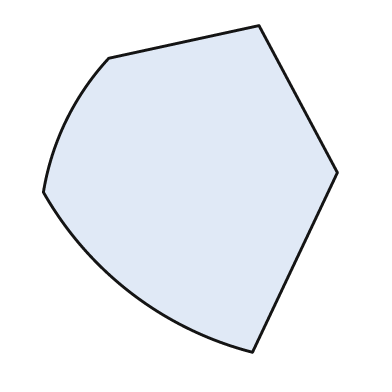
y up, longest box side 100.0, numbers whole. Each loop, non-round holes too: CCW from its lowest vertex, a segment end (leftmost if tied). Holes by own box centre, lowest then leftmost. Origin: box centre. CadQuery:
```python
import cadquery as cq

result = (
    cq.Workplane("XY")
    .moveTo(19.0, -50.0)
    .lineTo(45.0, 5.0)
    .lineTo(21.0, 50.0)
    .lineTo(-25.0, 40.0)
    .threePointArc((-38.0, 21.0), (-45.0, -1.0))
    .threePointArc((-18.0, -32.0), (19.0, -50.0))
    .close()
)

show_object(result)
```